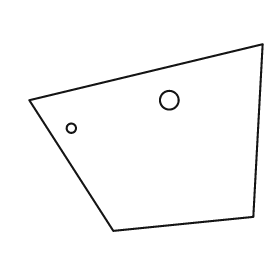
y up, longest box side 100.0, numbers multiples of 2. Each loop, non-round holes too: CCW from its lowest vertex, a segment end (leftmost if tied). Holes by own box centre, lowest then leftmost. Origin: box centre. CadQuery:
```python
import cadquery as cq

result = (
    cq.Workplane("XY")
    .moveTo(-14.0, -40.0)
    .lineTo(46.0, -34.0)
    .lineTo(50.0, 40.0)
    .lineTo(-50.0, 16.0)
    .close()
    .moveTo(-32.0, 4.0)
    .circle(2.0)
    .moveTo(10.0, 16.0)
    .circle(4.0)
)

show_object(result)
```